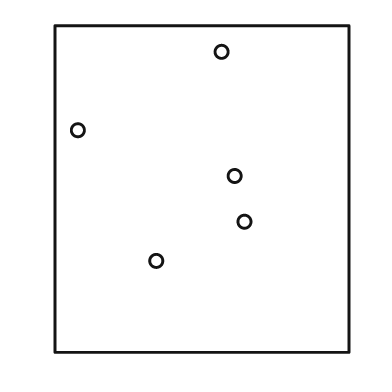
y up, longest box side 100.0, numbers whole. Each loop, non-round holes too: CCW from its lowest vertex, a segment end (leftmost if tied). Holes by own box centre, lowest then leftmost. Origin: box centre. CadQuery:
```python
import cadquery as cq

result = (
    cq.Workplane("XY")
    .moveTo(-45.0, -50.0)
    .lineTo(45.0, -50.0)
    .lineTo(45.0, 50.0)
    .lineTo(-45.0, 50.0)
    .close()
    .moveTo(-14.0, -22.0)
    .circle(2.0)
    .moveTo(13.0, -10.0)
    .circle(2.0)
    .moveTo(10.0, 4.0)
    .circle(2.0)
    .moveTo(-38.0, 18.0)
    .circle(2.0)
    .moveTo(6.0, 42.0)
    .circle(2.0)
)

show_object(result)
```